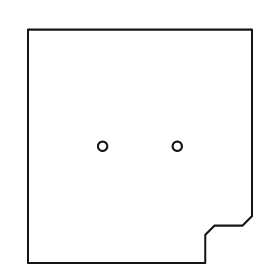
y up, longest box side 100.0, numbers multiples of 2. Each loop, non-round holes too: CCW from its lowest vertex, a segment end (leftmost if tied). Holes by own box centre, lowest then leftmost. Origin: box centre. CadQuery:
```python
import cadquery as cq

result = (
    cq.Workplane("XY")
    .moveTo(-48.0, -50.0)
    .lineTo(28.0, -50.0)
    .lineTo(28.0, -38.0)
    .lineTo(32.0, -34.0)
    .lineTo(44.0, -34.0)
    .lineTo(48.0, -30.0)
    .lineTo(48.0, 50.0)
    .lineTo(-48.0, 50.0)
    .close()
    .moveTo(-16.0, 0.0)
    .circle(2.0)
    .moveTo(16.0, 0.0)
    .circle(2.0)
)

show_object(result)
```